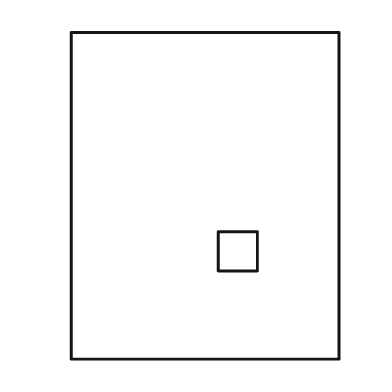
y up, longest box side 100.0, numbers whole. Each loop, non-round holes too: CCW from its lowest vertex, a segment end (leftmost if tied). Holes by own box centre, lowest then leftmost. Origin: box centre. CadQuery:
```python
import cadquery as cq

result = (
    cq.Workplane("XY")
    .moveTo(-41.0, -50.0)
    .lineTo(41.0, -50.0)
    .lineTo(41.0, 50.0)
    .lineTo(-41.0, 50.0)
    .close()
    .moveTo(4.0, -23.0)
    .lineTo(16.0, -23.0)
    .lineTo(16.0, -11.0)
    .lineTo(4.0, -11.0)
    .close()
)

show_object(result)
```